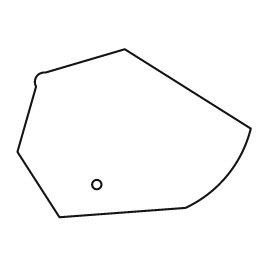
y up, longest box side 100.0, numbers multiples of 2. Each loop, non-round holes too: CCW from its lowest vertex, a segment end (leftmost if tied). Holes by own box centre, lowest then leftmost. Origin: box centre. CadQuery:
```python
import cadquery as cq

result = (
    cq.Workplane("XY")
    .moveTo(-32.0, -36.0)
    .lineTo(22.0, -32.0)
    .threePointArc((40.0, -18.0), (50.0, 2.0))
    .lineTo(-4.0, 36.0)
    .lineTo(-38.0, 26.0)
    .threePointArc((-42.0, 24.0), (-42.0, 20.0))
    .lineTo(-50.0, -8.0)
    .close()
    .moveTo(-16.0, -22.0)
    .circle(2.0)
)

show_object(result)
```